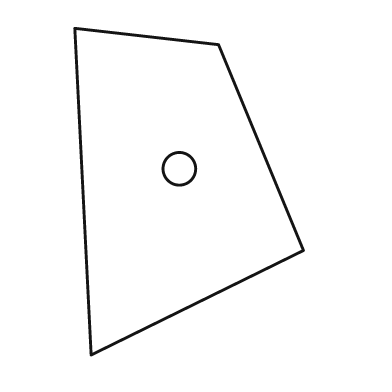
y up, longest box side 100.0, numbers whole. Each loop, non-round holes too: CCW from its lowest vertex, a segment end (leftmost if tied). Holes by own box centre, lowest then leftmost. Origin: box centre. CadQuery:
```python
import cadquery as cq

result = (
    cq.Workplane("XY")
    .moveTo(-30.0, -50.0)
    .lineTo(35.0, -18.0)
    .lineTo(9.0, 45.0)
    .lineTo(-35.0, 50.0)
    .close()
    .moveTo(-3.0, 7.0)
    .circle(5.0)
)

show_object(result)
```